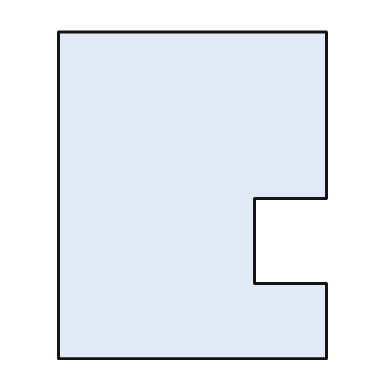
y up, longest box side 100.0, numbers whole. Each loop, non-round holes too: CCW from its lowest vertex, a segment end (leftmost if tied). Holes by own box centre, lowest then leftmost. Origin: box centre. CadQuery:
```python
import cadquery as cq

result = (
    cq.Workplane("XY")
    .moveTo(-41.0, -50.0)
    .lineTo(41.0, -50.0)
    .lineTo(41.0, -27.0)
    .lineTo(19.0, -27.0)
    .lineTo(19.0, -1.0)
    .lineTo(41.0, -1.0)
    .lineTo(41.0, 50.0)
    .lineTo(-41.0, 50.0)
    .close()
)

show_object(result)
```